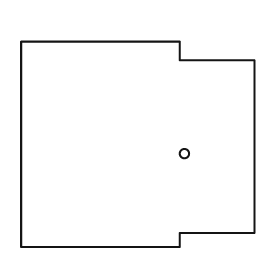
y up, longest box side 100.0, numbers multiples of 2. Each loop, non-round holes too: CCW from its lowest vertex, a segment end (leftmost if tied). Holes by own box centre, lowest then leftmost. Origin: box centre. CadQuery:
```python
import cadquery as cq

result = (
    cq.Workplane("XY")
    .moveTo(-50.0, -44.0)
    .lineTo(18.0, -44.0)
    .lineTo(18.0, -38.0)
    .lineTo(50.0, -38.0)
    .lineTo(50.0, 36.0)
    .lineTo(18.0, 36.0)
    .lineTo(18.0, 44.0)
    .lineTo(-50.0, 44.0)
    .close()
    .moveTo(20.0, -4.0)
    .circle(2.0)
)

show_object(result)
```